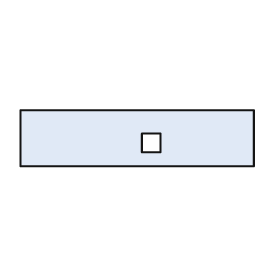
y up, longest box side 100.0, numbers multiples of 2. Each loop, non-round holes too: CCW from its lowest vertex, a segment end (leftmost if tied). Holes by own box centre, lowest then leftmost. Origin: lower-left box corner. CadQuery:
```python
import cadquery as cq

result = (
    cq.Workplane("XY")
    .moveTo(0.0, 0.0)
    .lineTo(100.0, 0.0)
    .lineTo(100.0, 24.0)
    .lineTo(0.0, 24.0)
    .close()
    .moveTo(52.0, 6.0)
    .lineTo(60.0, 6.0)
    .lineTo(60.0, 14.0)
    .lineTo(52.0, 14.0)
    .close()
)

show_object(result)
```